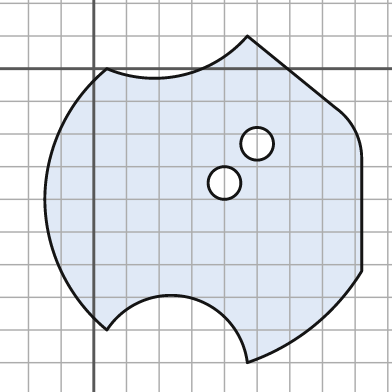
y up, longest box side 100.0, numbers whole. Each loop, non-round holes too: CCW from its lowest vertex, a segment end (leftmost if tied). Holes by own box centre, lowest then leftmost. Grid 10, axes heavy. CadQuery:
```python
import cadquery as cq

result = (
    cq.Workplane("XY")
    .moveTo(47.0, -90.0)
    .threePointArc((67.0, -79.0), (82.0, -62.0))
    .lineTo(82.0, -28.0)
    .threePointArc((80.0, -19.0), (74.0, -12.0))
    .lineTo(47.0, 10.0)
    .threePointArc((27.0, -2.0), (4.0, 0.0))
    .threePointArc((-10.0, -18.0), (-15.0, -40.0))
    .threePointArc((-10.0, -62.0), (4.0, -80.0))
    .threePointArc((29.0, -70.0), (47.0, -90.0))
    .close()
    .moveTo(40.0, -35.0)
    .circle(5.0)
    .moveTo(50.0, -23.0)
    .circle(5.0)
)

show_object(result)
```